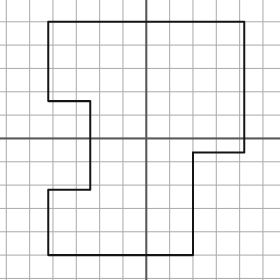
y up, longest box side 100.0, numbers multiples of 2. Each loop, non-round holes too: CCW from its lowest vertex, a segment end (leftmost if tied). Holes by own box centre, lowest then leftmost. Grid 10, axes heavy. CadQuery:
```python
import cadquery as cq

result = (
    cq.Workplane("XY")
    .moveTo(-42.0, -50.0)
    .lineTo(20.0, -50.0)
    .lineTo(20.0, -6.0)
    .lineTo(42.0, -6.0)
    .lineTo(42.0, 50.0)
    .lineTo(-42.0, 50.0)
    .lineTo(-42.0, 16.0)
    .lineTo(-24.0, 16.0)
    .lineTo(-24.0, -22.0)
    .lineTo(-42.0, -22.0)
    .close()
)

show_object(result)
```